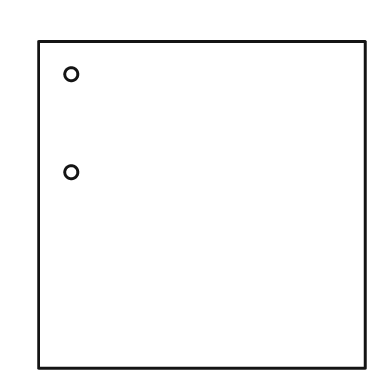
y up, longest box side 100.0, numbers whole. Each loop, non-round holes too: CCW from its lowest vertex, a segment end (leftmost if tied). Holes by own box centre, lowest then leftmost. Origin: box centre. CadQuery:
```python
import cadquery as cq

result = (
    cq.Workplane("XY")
    .moveTo(-50.0, -50.0)
    .lineTo(50.0, -50.0)
    .lineTo(50.0, 50.0)
    .lineTo(-50.0, 50.0)
    .close()
    .moveTo(-40.0, 10.0)
    .circle(2.0)
    .moveTo(-40.0, 40.0)
    .circle(2.0)
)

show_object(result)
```